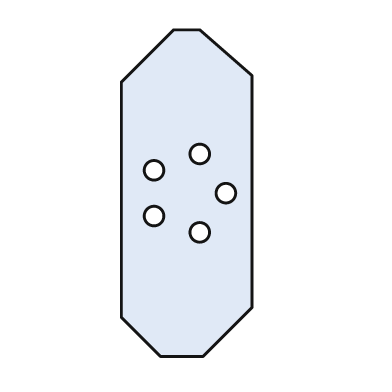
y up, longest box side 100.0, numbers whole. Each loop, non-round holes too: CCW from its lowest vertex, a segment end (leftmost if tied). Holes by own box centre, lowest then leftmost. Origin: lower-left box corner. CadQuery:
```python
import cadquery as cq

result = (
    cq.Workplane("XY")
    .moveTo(12.0, 0.0)
    .lineTo(25.0, 0.0)
    .lineTo(40.0, 15.0)
    .lineTo(40.0, 86.0)
    .lineTo(24.0, 100.0)
    .lineTo(16.0, 100.0)
    .lineTo(0.0, 84.0)
    .lineTo(0.0, 12.0)
    .close()
    .moveTo(24.0, 38.0)
    .circle(3.0)
    .moveTo(10.0, 43.0)
    .circle(3.0)
    .moveTo(32.0, 50.0)
    .circle(3.0)
    .moveTo(10.0, 57.0)
    .circle(3.0)
    .moveTo(24.0, 62.0)
    .circle(3.0)
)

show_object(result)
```